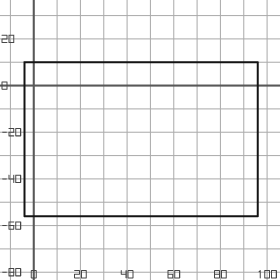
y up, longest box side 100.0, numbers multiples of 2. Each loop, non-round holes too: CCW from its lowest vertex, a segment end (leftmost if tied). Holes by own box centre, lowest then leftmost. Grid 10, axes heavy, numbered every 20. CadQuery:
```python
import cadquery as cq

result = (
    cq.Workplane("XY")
    .moveTo(-4.0, -56.0)
    .lineTo(96.0, -56.0)
    .lineTo(96.0, 10.0)
    .lineTo(-4.0, 10.0)
    .close()
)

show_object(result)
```